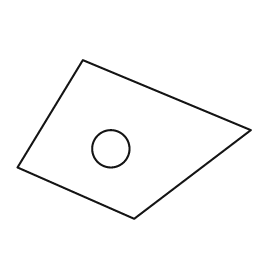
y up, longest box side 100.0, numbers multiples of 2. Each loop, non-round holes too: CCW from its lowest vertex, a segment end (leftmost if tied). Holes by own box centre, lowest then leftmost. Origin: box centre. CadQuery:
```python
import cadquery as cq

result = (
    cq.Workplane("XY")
    .moveTo(0.0, -34.0)
    .lineTo(50.0, 4.0)
    .lineTo(-22.0, 34.0)
    .lineTo(-50.0, -12.0)
    .close()
    .moveTo(-10.0, -4.0)
    .circle(8.0)
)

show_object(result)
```